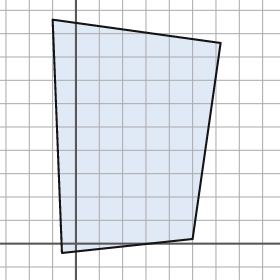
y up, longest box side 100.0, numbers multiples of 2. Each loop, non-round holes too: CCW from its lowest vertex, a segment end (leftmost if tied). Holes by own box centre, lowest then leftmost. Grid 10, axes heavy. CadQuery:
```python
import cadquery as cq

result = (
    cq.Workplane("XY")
    .moveTo(-6.0, -4.0)
    .lineTo(50.0, 2.0)
    .lineTo(62.0, 86.0)
    .lineTo(-10.0, 96.0)
    .close()
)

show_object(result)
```